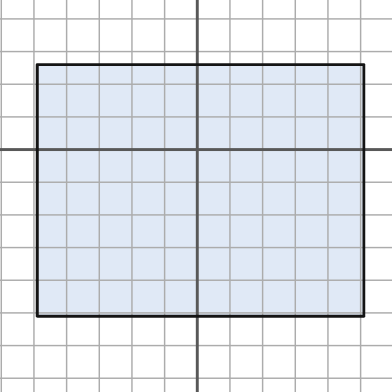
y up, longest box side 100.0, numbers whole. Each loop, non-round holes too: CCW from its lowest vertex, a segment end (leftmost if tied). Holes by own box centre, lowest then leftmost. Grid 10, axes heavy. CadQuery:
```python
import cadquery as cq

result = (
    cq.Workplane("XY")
    .moveTo(-49.0, -51.0)
    .lineTo(51.0, -51.0)
    .lineTo(51.0, 26.0)
    .lineTo(-49.0, 26.0)
    .close()
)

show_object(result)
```